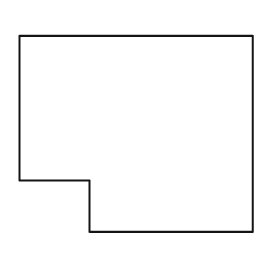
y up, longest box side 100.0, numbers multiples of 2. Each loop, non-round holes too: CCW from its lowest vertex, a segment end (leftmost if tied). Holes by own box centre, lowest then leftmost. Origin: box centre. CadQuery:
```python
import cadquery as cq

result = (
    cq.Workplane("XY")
    .moveTo(-20.0, -42.0)
    .lineTo(50.0, -42.0)
    .lineTo(50.0, 42.0)
    .lineTo(-50.0, 42.0)
    .lineTo(-50.0, -20.0)
    .lineTo(-20.0, -20.0)
    .close()
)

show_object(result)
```